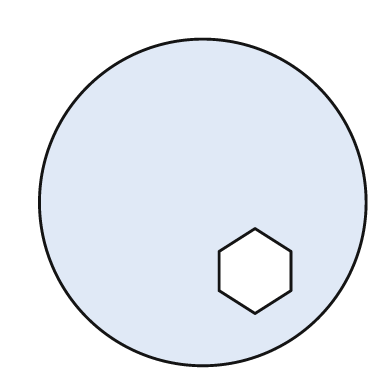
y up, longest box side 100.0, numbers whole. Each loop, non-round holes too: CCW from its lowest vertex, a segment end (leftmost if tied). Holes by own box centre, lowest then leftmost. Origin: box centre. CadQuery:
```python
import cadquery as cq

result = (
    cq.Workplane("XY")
    .moveTo(0.0, 0.0)
    .circle(50.0)
    .moveTo(16.0, -34.0)
    .lineTo(27.0, -27.0)
    .lineTo(27.0, -15.0)
    .lineTo(16.0, -8.0)
    .lineTo(5.0, -15.0)
    .lineTo(5.0, -27.0)
    .close()
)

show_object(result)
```